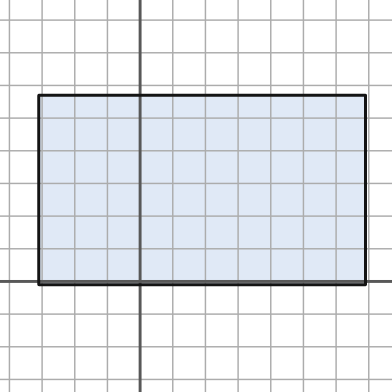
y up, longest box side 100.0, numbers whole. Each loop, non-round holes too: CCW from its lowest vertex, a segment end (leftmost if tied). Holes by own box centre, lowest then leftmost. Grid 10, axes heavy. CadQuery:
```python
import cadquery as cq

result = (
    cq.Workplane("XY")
    .moveTo(-31.0, -1.0)
    .lineTo(69.0, -1.0)
    .lineTo(69.0, 57.0)
    .lineTo(-31.0, 57.0)
    .close()
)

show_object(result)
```